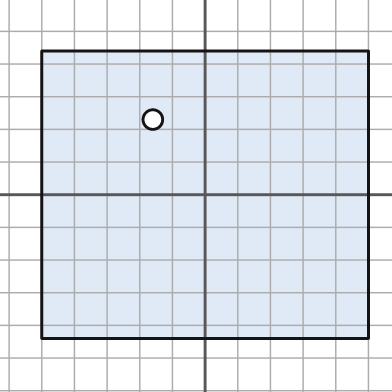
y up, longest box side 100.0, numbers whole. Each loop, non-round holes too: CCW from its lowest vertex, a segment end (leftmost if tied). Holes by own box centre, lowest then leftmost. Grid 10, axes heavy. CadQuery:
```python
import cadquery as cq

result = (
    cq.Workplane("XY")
    .moveTo(-50.0, -44.0)
    .lineTo(50.0, -44.0)
    .lineTo(50.0, 44.0)
    .lineTo(-50.0, 44.0)
    .close()
    .moveTo(-16.0, 23.0)
    .circle(3.0)
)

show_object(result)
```